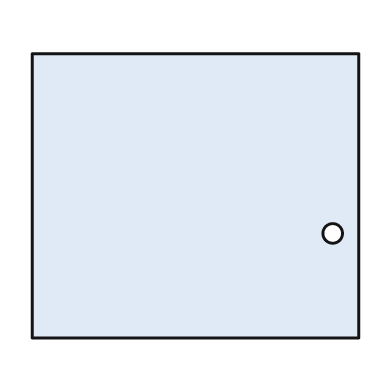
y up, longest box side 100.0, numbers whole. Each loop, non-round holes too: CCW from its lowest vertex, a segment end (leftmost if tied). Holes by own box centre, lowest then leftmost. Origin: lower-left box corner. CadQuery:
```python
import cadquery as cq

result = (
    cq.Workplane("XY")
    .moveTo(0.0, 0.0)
    .lineTo(100.0, 0.0)
    .lineTo(100.0, 87.0)
    .lineTo(0.0, 87.0)
    .close()
    .moveTo(92.0, 32.0)
    .circle(3.0)
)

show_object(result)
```